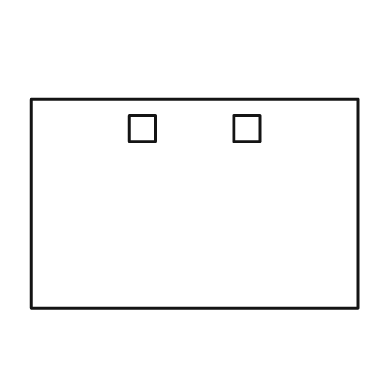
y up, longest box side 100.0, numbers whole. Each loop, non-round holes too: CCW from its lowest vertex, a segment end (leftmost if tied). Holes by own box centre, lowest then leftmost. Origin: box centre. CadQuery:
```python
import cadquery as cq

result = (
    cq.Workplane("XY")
    .moveTo(-50.0, -32.0)
    .lineTo(50.0, -32.0)
    .lineTo(50.0, 32.0)
    .lineTo(-50.0, 32.0)
    .close()
    .moveTo(-20.0, 19.0)
    .lineTo(-12.0, 19.0)
    .lineTo(-12.0, 27.0)
    .lineTo(-20.0, 27.0)
    .close()
    .moveTo(12.0, 19.0)
    .lineTo(20.0, 19.0)
    .lineTo(20.0, 27.0)
    .lineTo(12.0, 27.0)
    .close()
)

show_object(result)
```